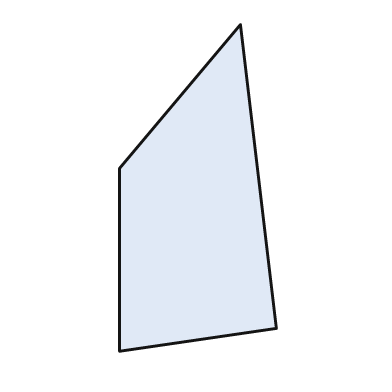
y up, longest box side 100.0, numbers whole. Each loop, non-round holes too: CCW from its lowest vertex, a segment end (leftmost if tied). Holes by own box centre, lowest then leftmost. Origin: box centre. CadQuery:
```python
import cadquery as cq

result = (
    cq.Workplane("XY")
    .moveTo(-24.0, -50.0)
    .lineTo(24.0, -43.0)
    .lineTo(13.0, 50.0)
    .lineTo(-24.0, 6.0)
    .close()
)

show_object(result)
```